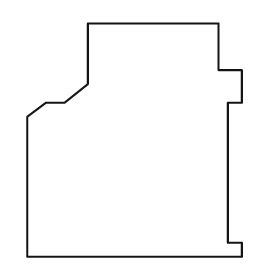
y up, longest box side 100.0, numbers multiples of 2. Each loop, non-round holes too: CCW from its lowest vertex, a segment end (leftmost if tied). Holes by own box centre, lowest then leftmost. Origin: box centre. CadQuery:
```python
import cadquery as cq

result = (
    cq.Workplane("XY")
    .moveTo(-46.0, -50.0)
    .lineTo(46.0, -50.0)
    .lineTo(46.0, -44.0)
    .lineTo(40.0, -44.0)
    .lineTo(40.0, 16.0)
    .lineTo(46.0, 16.0)
    .lineTo(46.0, 30.0)
    .lineTo(36.0, 30.0)
    .lineTo(36.0, 50.0)
    .lineTo(-20.0, 50.0)
    .lineTo(-20.0, 24.0)
    .lineTo(-30.0, 16.0)
    .lineTo(-38.0, 16.0)
    .lineTo(-46.0, 10.0)
    .close()
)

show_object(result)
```